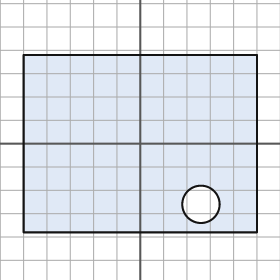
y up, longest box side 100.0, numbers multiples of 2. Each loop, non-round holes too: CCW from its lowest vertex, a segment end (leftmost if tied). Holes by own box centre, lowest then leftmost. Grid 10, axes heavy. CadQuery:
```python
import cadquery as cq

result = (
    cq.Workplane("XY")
    .moveTo(-50.0, -38.0)
    .lineTo(50.0, -38.0)
    .lineTo(50.0, 38.0)
    .lineTo(-50.0, 38.0)
    .close()
    .moveTo(26.0, -26.0)
    .circle(8.0)
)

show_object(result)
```